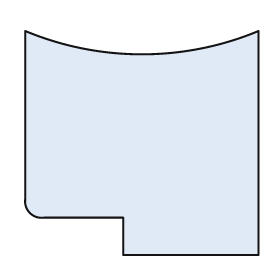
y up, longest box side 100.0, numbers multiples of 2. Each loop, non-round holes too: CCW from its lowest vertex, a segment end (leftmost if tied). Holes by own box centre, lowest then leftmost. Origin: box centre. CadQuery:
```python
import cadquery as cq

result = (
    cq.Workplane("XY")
    .moveTo(-8.0, -48.0)
    .lineTo(50.0, -48.0)
    .lineTo(50.0, 48.0)
    .threePointArc((0.0, 38.0), (-50.0, 48.0))
    .lineTo(-50.0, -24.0)
    .threePointArc((-48.0, -30.0), (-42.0, -32.0))
    .lineTo(-8.0, -32.0)
    .close()
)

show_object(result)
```